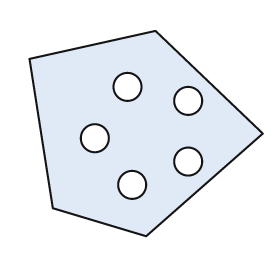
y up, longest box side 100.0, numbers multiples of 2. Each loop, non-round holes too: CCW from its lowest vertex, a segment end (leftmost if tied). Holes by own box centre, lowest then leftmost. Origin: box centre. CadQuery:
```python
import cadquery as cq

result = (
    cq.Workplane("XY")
    .moveTo(0.0, -44.0)
    .lineTo(50.0, 0.0)
    .lineTo(4.0, 44.0)
    .lineTo(-50.0, 32.0)
    .lineTo(-40.0, -32.0)
    .close()
    .moveTo(-6.0, -22.0)
    .circle(6.0)
    .moveTo(18.0, -12.0)
    .circle(6.0)
    .moveTo(-22.0, -2.0)
    .circle(6.0)
    .moveTo(18.0, 14.0)
    .circle(6.0)
    .moveTo(-8.0, 20.0)
    .circle(6.0)
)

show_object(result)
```